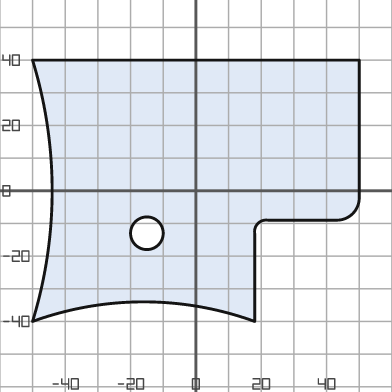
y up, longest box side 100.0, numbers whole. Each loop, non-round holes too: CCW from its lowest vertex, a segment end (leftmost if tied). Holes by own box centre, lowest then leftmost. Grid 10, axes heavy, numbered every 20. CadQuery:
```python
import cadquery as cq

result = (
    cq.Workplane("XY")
    .moveTo(-50.0, -40.0)
    .threePointArc((-16.0, -34.0), (18.0, -40.0))
    .lineTo(18.0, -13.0)
    .threePointArc((19.0, -10.0), (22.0, -9.0))
    .lineTo(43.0, -9.0)
    .threePointArc((48.0, -7.0), (50.0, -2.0))
    .lineTo(50.0, 40.0)
    .lineTo(-50.0, 40.0)
    .threePointArc((-44.0, 0.0), (-50.0, -40.0))
    .close()
    .moveTo(-15.0, -13.0)
    .circle(5.0)
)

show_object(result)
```